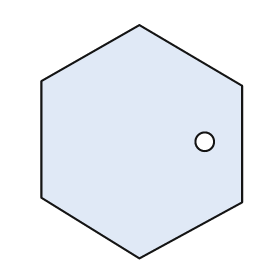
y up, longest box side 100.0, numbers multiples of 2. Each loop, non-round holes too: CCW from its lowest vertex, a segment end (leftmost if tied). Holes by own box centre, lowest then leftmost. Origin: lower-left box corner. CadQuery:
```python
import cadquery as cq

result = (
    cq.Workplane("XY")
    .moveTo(42.0, 0.0)
    .lineTo(86.0, 24.0)
    .lineTo(86.0, 74.0)
    .lineTo(42.0, 100.0)
    .lineTo(0.0, 76.0)
    .lineTo(0.0, 26.0)
    .close()
    .moveTo(70.0, 50.0)
    .circle(4.0)
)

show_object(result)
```